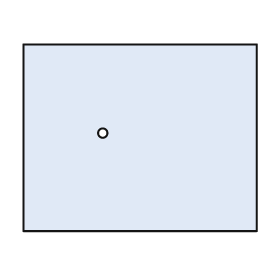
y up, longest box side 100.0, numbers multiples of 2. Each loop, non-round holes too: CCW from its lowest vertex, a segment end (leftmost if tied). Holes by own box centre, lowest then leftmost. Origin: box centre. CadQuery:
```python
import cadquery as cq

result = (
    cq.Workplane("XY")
    .moveTo(-50.0, -40.0)
    .lineTo(50.0, -40.0)
    .lineTo(50.0, 40.0)
    .lineTo(-50.0, 40.0)
    .close()
    .moveTo(-16.0, 2.0)
    .circle(2.0)
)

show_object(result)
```